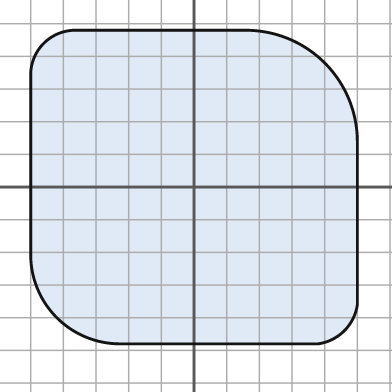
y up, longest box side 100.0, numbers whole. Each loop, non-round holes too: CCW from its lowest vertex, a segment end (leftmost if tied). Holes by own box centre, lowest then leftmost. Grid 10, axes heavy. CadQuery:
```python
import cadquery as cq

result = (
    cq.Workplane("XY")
    .moveTo(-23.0, -48.0)
    .lineTo(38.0, -48.0)
    .threePointArc((46.0, -44.0), (50.0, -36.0))
    .lineTo(50.0, 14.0)
    .threePointArc((40.0, 38.0), (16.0, 48.0))
    .lineTo(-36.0, 48.0)
    .threePointArc((-46.0, 44.0), (-50.0, 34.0))
    .lineTo(-50.0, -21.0)
    .threePointArc((-42.0, -40.0), (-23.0, -48.0))
    .close()
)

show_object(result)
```